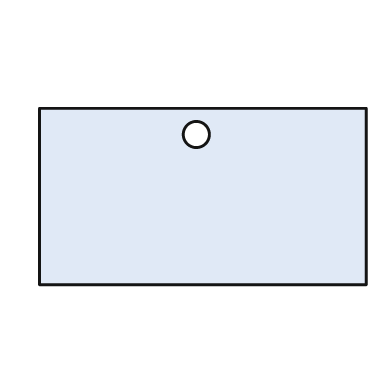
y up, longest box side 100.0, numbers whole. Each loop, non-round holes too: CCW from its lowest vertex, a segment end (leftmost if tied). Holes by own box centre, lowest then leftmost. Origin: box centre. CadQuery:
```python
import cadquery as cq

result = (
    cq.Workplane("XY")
    .moveTo(-50.0, -27.0)
    .lineTo(50.0, -27.0)
    .lineTo(50.0, 27.0)
    .lineTo(-50.0, 27.0)
    .close()
    .moveTo(-2.0, 19.0)
    .circle(4.0)
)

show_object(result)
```